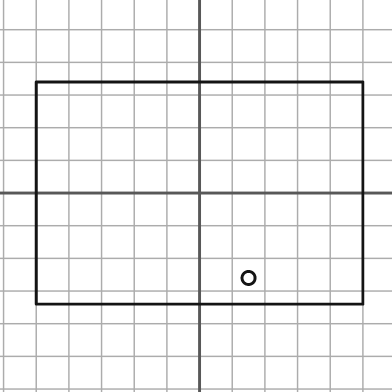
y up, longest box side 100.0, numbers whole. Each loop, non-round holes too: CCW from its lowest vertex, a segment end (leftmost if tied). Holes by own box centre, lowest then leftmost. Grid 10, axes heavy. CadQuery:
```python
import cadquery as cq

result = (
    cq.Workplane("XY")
    .moveTo(-50.0, -34.0)
    .lineTo(50.0, -34.0)
    .lineTo(50.0, 34.0)
    .lineTo(-50.0, 34.0)
    .close()
    .moveTo(15.0, -26.0)
    .circle(2.0)
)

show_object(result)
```